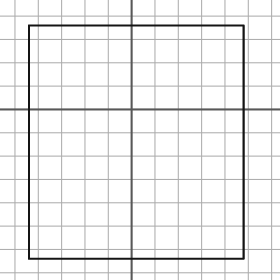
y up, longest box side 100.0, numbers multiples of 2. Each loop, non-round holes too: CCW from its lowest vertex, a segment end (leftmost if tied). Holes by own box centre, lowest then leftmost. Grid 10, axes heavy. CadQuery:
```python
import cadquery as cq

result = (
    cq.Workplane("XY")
    .moveTo(-44.0, -64.0)
    .lineTo(48.0, -64.0)
    .lineTo(48.0, 36.0)
    .lineTo(-44.0, 36.0)
    .close()
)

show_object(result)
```